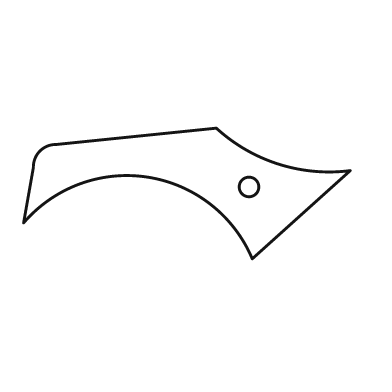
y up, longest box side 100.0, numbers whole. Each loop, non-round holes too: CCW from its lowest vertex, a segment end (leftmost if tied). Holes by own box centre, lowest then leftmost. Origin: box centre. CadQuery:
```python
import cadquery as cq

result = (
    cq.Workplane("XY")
    .moveTo(20.0, -20.0)
    .lineTo(50.0, 7.0)
    .threePointArc((28.0, 9.0), (9.0, 20.0))
    .lineTo(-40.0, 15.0)
    .threePointArc((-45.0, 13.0), (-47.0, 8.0))
    .lineTo(-50.0, -9.0)
    .threePointArc((-12.0, 5.0), (20.0, -20.0))
    .close()
    .moveTo(19.0, 2.0)
    .circle(3.0)
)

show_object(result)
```